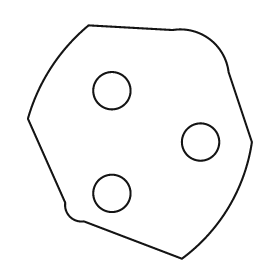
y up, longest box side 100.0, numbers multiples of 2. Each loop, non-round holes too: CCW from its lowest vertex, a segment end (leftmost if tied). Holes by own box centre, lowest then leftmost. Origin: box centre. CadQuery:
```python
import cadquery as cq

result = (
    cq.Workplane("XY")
    .moveTo(18.0, -50.0)
    .threePointArc((38.0, -28.0), (48.0, 0.0))
    .lineTo(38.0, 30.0)
    .threePointArc((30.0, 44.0), (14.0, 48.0))
    .lineTo(-22.0, 50.0)
    .threePointArc((-38.0, 32.0), (-48.0, 10.0))
    .lineTo(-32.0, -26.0)
    .threePointArc((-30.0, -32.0), (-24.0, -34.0))
    .close()
    .moveTo(-12.0, -22.0)
    .circle(8.0)
    .moveTo(26.0, 0.0)
    .circle(8.0)
    .moveTo(-12.0, 22.0)
    .circle(8.0)
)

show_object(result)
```